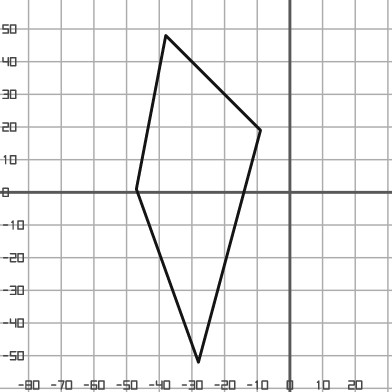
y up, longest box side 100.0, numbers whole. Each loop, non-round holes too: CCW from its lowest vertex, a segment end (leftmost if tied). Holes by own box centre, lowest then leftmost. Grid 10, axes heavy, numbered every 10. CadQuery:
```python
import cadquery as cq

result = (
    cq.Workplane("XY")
    .moveTo(-28.0, -52.0)
    .lineTo(-9.0, 19.0)
    .lineTo(-38.0, 48.0)
    .lineTo(-47.0, 1.0)
    .close()
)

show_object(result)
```